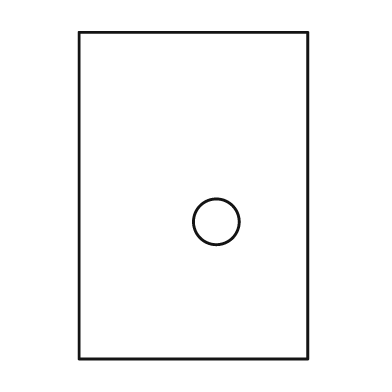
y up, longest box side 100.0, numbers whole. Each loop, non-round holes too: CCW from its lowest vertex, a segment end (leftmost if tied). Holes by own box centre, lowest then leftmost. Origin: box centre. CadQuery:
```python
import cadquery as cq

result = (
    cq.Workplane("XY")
    .moveTo(-35.0, -50.0)
    .lineTo(35.0, -50.0)
    .lineTo(35.0, 50.0)
    .lineTo(-35.0, 50.0)
    .close()
    .moveTo(7.0, -8.0)
    .circle(7.0)
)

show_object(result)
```